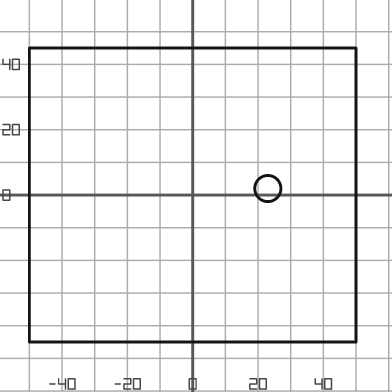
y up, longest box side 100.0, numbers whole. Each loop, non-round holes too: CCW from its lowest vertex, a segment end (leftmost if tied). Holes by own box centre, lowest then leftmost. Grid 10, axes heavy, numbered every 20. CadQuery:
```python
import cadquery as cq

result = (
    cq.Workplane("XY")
    .moveTo(-50.0, -45.0)
    .lineTo(50.0, -45.0)
    .lineTo(50.0, 45.0)
    .lineTo(-50.0, 45.0)
    .close()
    .moveTo(23.0, 2.0)
    .circle(4.0)
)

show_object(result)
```